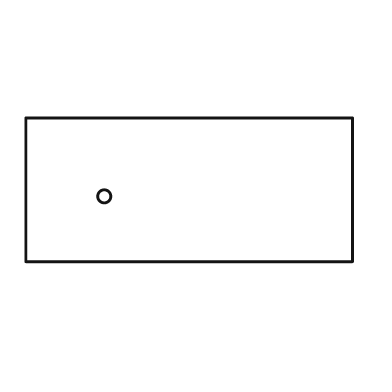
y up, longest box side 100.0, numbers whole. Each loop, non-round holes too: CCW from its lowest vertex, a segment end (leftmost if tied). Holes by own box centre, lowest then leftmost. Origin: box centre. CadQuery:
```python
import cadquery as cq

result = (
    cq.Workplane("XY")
    .moveTo(-50.0, -22.0)
    .lineTo(50.0, -22.0)
    .lineTo(50.0, 22.0)
    .lineTo(-50.0, 22.0)
    .close()
    .moveTo(-26.0, -2.0)
    .circle(2.0)
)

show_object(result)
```